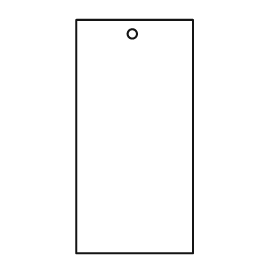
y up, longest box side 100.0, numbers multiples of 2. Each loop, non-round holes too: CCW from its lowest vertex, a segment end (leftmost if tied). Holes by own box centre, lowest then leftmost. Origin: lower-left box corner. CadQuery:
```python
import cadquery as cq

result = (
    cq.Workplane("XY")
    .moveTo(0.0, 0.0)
    .lineTo(50.0, 0.0)
    .lineTo(50.0, 100.0)
    .lineTo(0.0, 100.0)
    .close()
    .moveTo(24.0, 94.0)
    .circle(2.0)
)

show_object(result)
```